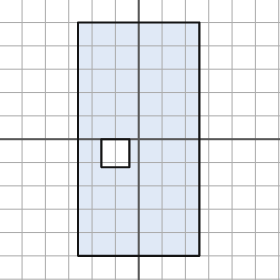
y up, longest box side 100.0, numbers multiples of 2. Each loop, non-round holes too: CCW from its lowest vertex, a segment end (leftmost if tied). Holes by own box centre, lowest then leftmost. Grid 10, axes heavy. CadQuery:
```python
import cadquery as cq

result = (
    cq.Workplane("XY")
    .moveTo(-26.0, -50.0)
    .lineTo(26.0, -50.0)
    .lineTo(26.0, 50.0)
    .lineTo(-26.0, 50.0)
    .close()
    .moveTo(-16.0, -12.0)
    .lineTo(-4.0, -12.0)
    .lineTo(-4.0, 0.0)
    .lineTo(-16.0, 0.0)
    .close()
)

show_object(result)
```